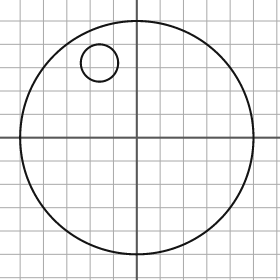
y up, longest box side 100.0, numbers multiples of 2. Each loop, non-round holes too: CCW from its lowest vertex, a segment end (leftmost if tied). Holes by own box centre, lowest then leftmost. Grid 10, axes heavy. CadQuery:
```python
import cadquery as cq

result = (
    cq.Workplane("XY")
    .moveTo(0.0, 0.0)
    .circle(50.0)
    .moveTo(-16.0, 32.0)
    .circle(8.0)
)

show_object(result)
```